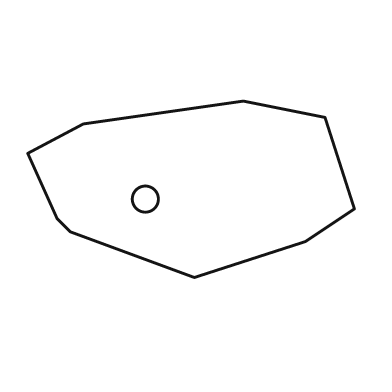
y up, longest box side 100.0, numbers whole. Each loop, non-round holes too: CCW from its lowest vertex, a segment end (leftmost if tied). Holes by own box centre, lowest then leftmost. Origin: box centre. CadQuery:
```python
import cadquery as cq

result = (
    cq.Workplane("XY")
    .moveTo(1.0, -27.0)
    .lineTo(35.0, -16.0)
    .lineTo(50.0, -6.0)
    .lineTo(41.0, 22.0)
    .lineTo(16.0, 27.0)
    .lineTo(-33.0, 20.0)
    .lineTo(-50.0, 11.0)
    .lineTo(-41.0, -9.0)
    .lineTo(-37.0, -13.0)
    .close()
    .moveTo(-14.0, -3.0)
    .circle(4.0)
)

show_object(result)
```